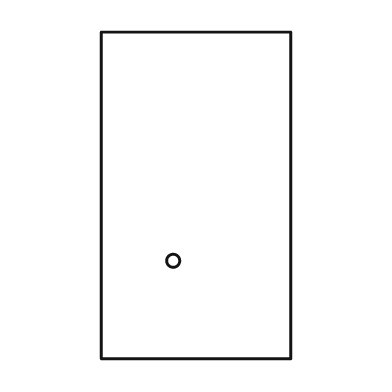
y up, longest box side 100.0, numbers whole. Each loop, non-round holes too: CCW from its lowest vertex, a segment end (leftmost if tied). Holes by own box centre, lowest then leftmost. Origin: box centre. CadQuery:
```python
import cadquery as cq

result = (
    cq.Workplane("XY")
    .moveTo(-29.0, -50.0)
    .lineTo(29.0, -50.0)
    .lineTo(29.0, 50.0)
    .lineTo(-29.0, 50.0)
    .close()
    .moveTo(-7.0, -20.0)
    .circle(2.0)
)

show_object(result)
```